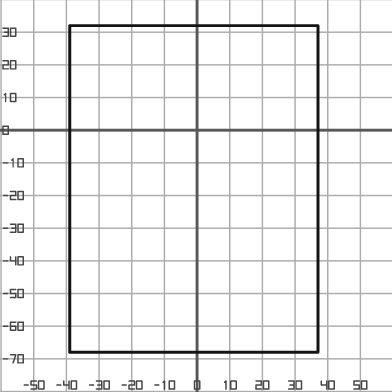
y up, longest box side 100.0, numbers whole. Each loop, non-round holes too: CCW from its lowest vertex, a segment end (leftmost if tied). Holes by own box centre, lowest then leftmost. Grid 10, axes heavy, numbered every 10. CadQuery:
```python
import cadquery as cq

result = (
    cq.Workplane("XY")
    .moveTo(-39.0, -68.0)
    .lineTo(37.0, -68.0)
    .lineTo(37.0, 32.0)
    .lineTo(-39.0, 32.0)
    .close()
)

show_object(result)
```